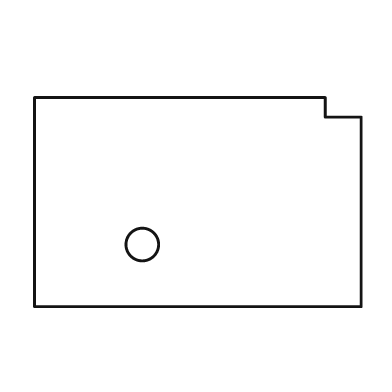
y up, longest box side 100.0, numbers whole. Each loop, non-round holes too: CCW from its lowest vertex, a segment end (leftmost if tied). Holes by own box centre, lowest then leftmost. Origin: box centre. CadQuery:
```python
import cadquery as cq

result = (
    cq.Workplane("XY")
    .moveTo(-50.0, -32.0)
    .lineTo(50.0, -32.0)
    .lineTo(50.0, 26.0)
    .lineTo(39.0, 26.0)
    .lineTo(39.0, 32.0)
    .lineTo(-50.0, 32.0)
    .close()
    .moveTo(-17.0, -13.0)
    .circle(5.0)
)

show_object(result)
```